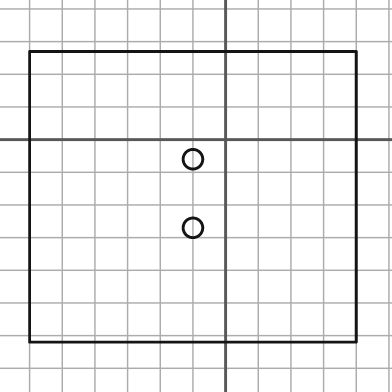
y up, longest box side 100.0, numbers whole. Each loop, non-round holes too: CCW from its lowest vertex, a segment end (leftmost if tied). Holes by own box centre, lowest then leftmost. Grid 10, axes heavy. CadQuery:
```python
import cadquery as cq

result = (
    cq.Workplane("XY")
    .moveTo(-60.0, -62.0)
    .lineTo(40.0, -62.0)
    .lineTo(40.0, 27.0)
    .lineTo(-60.0, 27.0)
    .close()
    .moveTo(-10.0, -27.0)
    .circle(3.0)
    .moveTo(-10.0, -6.0)
    .circle(3.0)
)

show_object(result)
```